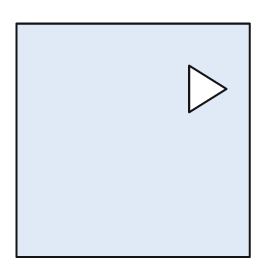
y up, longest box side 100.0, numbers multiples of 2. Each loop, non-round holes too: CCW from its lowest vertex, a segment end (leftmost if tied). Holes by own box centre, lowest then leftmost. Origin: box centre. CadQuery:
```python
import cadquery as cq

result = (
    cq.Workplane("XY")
    .moveTo(-50.0, -50.0)
    .lineTo(50.0, -50.0)
    .lineTo(50.0, 50.0)
    .lineTo(-50.0, 50.0)
    .close()
    .moveTo(24.0, 12.0)
    .lineTo(40.0, 22.0)
    .lineTo(24.0, 32.0)
    .close()
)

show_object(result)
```